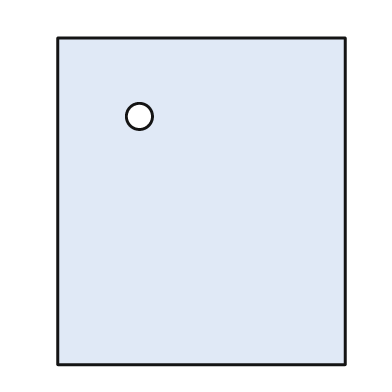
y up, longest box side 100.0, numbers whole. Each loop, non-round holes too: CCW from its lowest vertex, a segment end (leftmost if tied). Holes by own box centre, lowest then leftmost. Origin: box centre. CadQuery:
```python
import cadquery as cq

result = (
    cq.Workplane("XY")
    .moveTo(-44.0, -50.0)
    .lineTo(44.0, -50.0)
    .lineTo(44.0, 50.0)
    .lineTo(-44.0, 50.0)
    .close()
    .moveTo(-19.0, 26.0)
    .circle(4.0)
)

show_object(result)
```